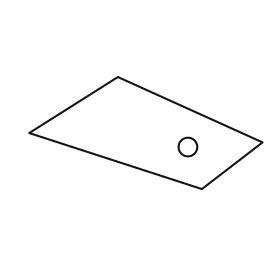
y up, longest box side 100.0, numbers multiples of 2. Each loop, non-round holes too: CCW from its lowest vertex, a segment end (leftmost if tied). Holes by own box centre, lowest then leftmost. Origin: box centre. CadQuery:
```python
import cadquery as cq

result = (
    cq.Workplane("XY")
    .moveTo(24.0, -24.0)
    .lineTo(50.0, -4.0)
    .lineTo(-12.0, 24.0)
    .lineTo(-50.0, 0.0)
    .close()
    .moveTo(18.0, -6.0)
    .circle(4.0)
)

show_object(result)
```